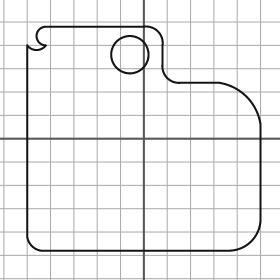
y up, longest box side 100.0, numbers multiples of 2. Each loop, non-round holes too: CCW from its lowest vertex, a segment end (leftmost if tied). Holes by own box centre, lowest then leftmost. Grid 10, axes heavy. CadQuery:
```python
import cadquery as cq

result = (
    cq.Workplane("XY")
    .moveTo(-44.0, -48.0)
    .lineTo(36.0, -48.0)
    .threePointArc((46.0, -44.0), (50.0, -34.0))
    .lineTo(50.0, 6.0)
    .threePointArc((44.0, 18.0), (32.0, 24.0))
    .lineTo(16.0, 24.0)
    .threePointArc((10.0, 26.0), (8.0, 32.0))
    .lineTo(8.0, 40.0)
    .threePointArc((6.0, 46.0), (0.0, 48.0))
    .lineTo(-42.0, 48.0)
    .threePointArc((-46.0, 44.0), (-42.0, 40.0))
    .threePointArc((-46.0, 38.0), (-50.0, 40.0))
    .lineTo(-50.0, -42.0)
    .threePointArc((-48.0, -46.0), (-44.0, -48.0))
    .close()
    .moveTo(-6.0, 36.0)
    .circle(8.0)
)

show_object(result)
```